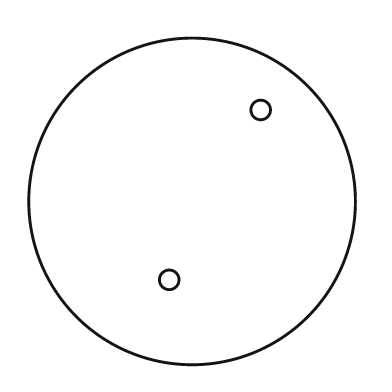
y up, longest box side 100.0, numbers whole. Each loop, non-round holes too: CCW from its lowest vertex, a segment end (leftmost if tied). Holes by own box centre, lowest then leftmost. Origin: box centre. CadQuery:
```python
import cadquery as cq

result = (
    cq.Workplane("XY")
    .moveTo(0.0, 0.0)
    .circle(50.0)
    .moveTo(-7.0, -24.0)
    .circle(3.0)
    .moveTo(21.0, 28.0)
    .circle(3.0)
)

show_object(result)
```